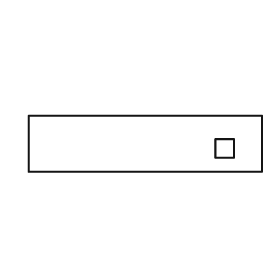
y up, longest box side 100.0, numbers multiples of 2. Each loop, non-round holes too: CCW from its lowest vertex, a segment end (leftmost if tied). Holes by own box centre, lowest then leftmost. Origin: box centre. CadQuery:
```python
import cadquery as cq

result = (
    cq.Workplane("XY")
    .moveTo(-50.0, -12.0)
    .lineTo(50.0, -12.0)
    .lineTo(50.0, 12.0)
    .lineTo(-50.0, 12.0)
    .close()
    .moveTo(30.0, -6.0)
    .lineTo(38.0, -6.0)
    .lineTo(38.0, 2.0)
    .lineTo(30.0, 2.0)
    .close()
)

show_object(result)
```